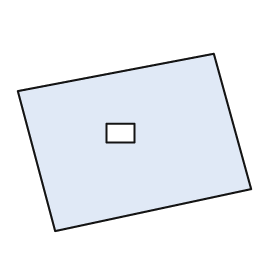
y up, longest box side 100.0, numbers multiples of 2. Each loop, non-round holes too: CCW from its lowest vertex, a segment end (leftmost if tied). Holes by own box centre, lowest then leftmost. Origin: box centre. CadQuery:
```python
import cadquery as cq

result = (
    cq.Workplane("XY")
    .moveTo(-34.0, -38.0)
    .lineTo(50.0, -20.0)
    .lineTo(34.0, 38.0)
    .lineTo(-50.0, 22.0)
    .close()
    .moveTo(-12.0, 0.0)
    .lineTo(0.0, 0.0)
    .lineTo(0.0, 8.0)
    .lineTo(-12.0, 8.0)
    .close()
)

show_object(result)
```